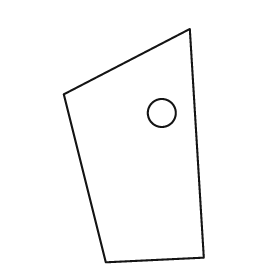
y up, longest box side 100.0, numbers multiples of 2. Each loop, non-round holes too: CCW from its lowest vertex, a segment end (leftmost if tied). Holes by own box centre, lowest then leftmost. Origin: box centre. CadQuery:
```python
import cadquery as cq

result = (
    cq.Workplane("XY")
    .moveTo(-12.0, -50.0)
    .lineTo(30.0, -48.0)
    .lineTo(24.0, 50.0)
    .lineTo(-30.0, 22.0)
    .close()
    .moveTo(12.0, 14.0)
    .circle(6.0)
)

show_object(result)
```